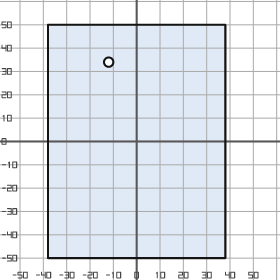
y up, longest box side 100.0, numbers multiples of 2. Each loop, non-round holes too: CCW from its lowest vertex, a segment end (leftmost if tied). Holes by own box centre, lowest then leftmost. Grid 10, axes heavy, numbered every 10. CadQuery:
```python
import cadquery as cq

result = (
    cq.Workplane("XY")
    .moveTo(-38.0, -50.0)
    .lineTo(38.0, -50.0)
    .lineTo(38.0, 50.0)
    .lineTo(-38.0, 50.0)
    .close()
    .moveTo(-12.0, 34.0)
    .circle(2.0)
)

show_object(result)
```